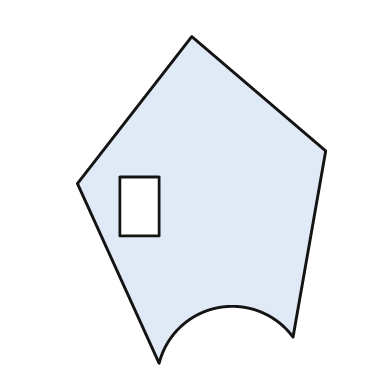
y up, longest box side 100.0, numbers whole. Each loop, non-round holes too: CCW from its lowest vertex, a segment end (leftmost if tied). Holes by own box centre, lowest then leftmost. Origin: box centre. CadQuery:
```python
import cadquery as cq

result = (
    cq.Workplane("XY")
    .moveTo(-13.0, -50.0)
    .threePointArc((5.0, -33.0), (28.0, -42.0))
    .lineTo(38.0, 15.0)
    .lineTo(-3.0, 50.0)
    .lineTo(-38.0, 5.0)
    .close()
    .moveTo(-25.0, -11.0)
    .lineTo(-13.0, -11.0)
    .lineTo(-13.0, 7.0)
    .lineTo(-25.0, 7.0)
    .close()
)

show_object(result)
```